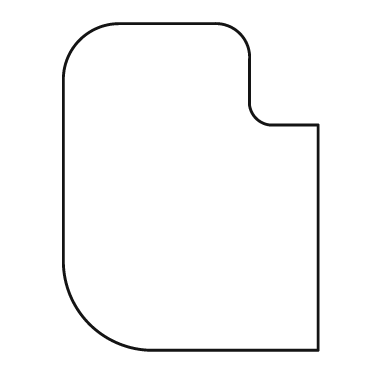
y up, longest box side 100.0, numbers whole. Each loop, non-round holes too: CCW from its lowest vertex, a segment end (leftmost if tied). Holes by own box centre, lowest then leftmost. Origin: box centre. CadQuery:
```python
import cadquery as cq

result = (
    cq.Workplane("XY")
    .moveTo(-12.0, -50.0)
    .lineTo(39.0, -50.0)
    .lineTo(39.0, 19.0)
    .lineTo(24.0, 19.0)
    .threePointArc((20.0, 21.0), (18.0, 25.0))
    .lineTo(18.0, 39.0)
    .threePointArc((15.0, 47.0), (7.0, 50.0))
    .lineTo(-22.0, 50.0)
    .threePointArc((-34.0, 45.0), (-39.0, 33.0))
    .lineTo(-39.0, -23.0)
    .threePointArc((-31.0, -42.0), (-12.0, -50.0))
    .close()
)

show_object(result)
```